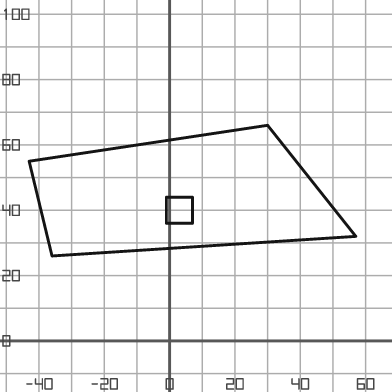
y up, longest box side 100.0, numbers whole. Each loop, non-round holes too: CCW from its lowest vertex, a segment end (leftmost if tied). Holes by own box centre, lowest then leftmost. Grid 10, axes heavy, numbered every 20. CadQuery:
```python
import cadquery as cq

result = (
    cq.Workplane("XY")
    .moveTo(-36.0, 26.0)
    .lineTo(57.0, 32.0)
    .lineTo(30.0, 66.0)
    .lineTo(-43.0, 55.0)
    .close()
    .moveTo(-1.0, 36.0)
    .lineTo(7.0, 36.0)
    .lineTo(7.0, 44.0)
    .lineTo(-1.0, 44.0)
    .close()
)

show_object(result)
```